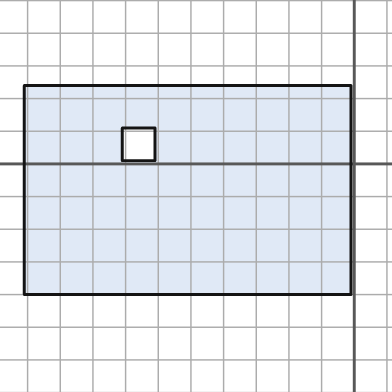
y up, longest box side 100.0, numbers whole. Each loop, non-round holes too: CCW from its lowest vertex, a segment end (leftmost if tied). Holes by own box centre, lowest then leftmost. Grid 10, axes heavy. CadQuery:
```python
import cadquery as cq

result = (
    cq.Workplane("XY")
    .moveTo(-101.0, -40.0)
    .lineTo(-1.0, -40.0)
    .lineTo(-1.0, 24.0)
    .lineTo(-101.0, 24.0)
    .close()
    .moveTo(-71.0, 1.0)
    .lineTo(-61.0, 1.0)
    .lineTo(-61.0, 11.0)
    .lineTo(-71.0, 11.0)
    .close()
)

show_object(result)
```